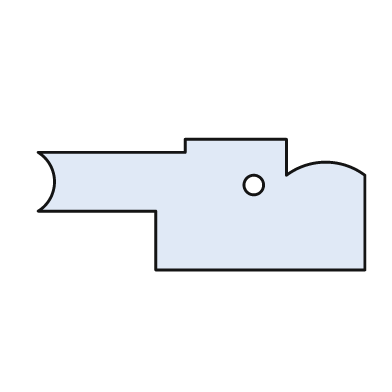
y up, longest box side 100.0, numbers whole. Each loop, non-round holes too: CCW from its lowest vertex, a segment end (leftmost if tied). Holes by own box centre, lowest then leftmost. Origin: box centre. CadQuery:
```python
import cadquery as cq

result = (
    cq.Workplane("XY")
    .moveTo(-14.0, -20.0)
    .lineTo(50.0, -20.0)
    .lineTo(50.0, 9.0)
    .threePointArc((38.0, 13.0), (26.0, 9.0))
    .lineTo(26.0, 20.0)
    .lineTo(-5.0, 20.0)
    .lineTo(-5.0, 16.0)
    .lineTo(-50.0, 16.0)
    .threePointArc((-45.0, 7.0), (-50.0, -2.0))
    .lineTo(-14.0, -2.0)
    .close()
    .moveTo(16.0, 6.0)
    .circle(3.0)
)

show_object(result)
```